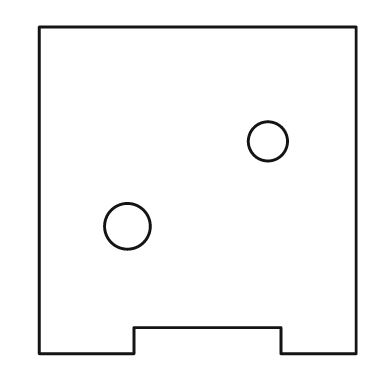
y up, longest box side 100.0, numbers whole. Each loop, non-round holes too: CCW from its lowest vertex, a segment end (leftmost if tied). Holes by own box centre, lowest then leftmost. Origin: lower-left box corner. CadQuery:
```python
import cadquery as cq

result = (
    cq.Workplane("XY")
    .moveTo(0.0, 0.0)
    .lineTo(29.0, 0.0)
    .lineTo(29.0, 8.0)
    .lineTo(74.0, 8.0)
    .lineTo(74.0, 0.0)
    .lineTo(97.0, 0.0)
    .lineTo(97.0, 100.0)
    .lineTo(0.0, 100.0)
    .close()
    .moveTo(27.0, 39.0)
    .circle(7.0)
    .moveTo(70.0, 65.0)
    .circle(6.0)
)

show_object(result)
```